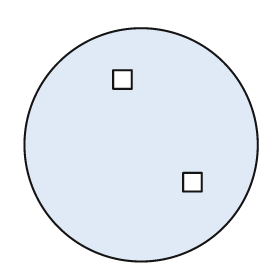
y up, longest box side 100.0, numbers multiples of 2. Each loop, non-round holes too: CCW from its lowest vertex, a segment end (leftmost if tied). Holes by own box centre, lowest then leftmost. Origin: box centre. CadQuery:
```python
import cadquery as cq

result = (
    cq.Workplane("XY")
    .moveTo(0.0, 0.0)
    .circle(50.0)
    .moveTo(18.0, -20.0)
    .lineTo(26.0, -20.0)
    .lineTo(26.0, -12.0)
    .lineTo(18.0, -12.0)
    .close()
    .moveTo(-12.0, 24.0)
    .lineTo(-4.0, 24.0)
    .lineTo(-4.0, 32.0)
    .lineTo(-12.0, 32.0)
    .close()
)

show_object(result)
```